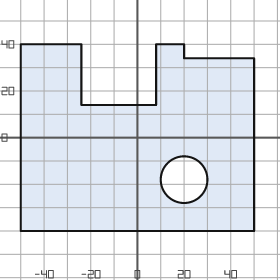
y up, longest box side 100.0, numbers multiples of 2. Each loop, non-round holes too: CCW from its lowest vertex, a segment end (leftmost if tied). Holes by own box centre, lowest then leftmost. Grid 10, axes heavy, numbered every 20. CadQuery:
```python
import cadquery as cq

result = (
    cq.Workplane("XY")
    .moveTo(-50.0, -40.0)
    .lineTo(50.0, -40.0)
    .lineTo(50.0, 34.0)
    .lineTo(20.0, 34.0)
    .lineTo(20.0, 40.0)
    .lineTo(8.0, 40.0)
    .lineTo(8.0, 14.0)
    .lineTo(-24.0, 14.0)
    .lineTo(-24.0, 40.0)
    .lineTo(-50.0, 40.0)
    .close()
    .moveTo(20.0, -18.0)
    .circle(10.0)
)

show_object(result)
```